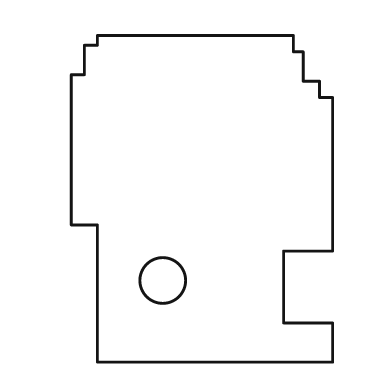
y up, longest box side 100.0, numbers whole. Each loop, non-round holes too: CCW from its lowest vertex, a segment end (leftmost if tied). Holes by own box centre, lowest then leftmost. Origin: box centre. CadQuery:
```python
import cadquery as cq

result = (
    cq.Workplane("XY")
    .moveTo(-32.0, -50.0)
    .lineTo(40.0, -50.0)
    .lineTo(40.0, -38.0)
    .lineTo(25.0, -38.0)
    .lineTo(25.0, -16.0)
    .lineTo(40.0, -16.0)
    .lineTo(40.0, 31.0)
    .lineTo(36.0, 31.0)
    .lineTo(36.0, 36.0)
    .lineTo(31.0, 36.0)
    .lineTo(31.0, 45.0)
    .lineTo(28.0, 45.0)
    .lineTo(28.0, 50.0)
    .lineTo(-32.0, 50.0)
    .lineTo(-32.0, 47.0)
    .lineTo(-36.0, 47.0)
    .lineTo(-36.0, 38.0)
    .lineTo(-40.0, 38.0)
    .lineTo(-40.0, -8.0)
    .lineTo(-32.0, -8.0)
    .close()
    .moveTo(-12.0, -25.0)
    .circle(7.0)
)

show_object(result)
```